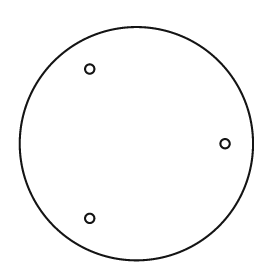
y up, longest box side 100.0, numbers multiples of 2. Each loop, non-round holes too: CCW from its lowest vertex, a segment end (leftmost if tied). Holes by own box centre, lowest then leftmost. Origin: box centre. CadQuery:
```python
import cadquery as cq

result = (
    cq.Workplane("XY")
    .moveTo(0.0, 0.0)
    .circle(50.0)
    .moveTo(-20.0, -32.0)
    .circle(2.0)
    .moveTo(38.0, 0.0)
    .circle(2.0)
    .moveTo(-20.0, 32.0)
    .circle(2.0)
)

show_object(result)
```